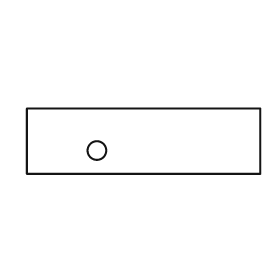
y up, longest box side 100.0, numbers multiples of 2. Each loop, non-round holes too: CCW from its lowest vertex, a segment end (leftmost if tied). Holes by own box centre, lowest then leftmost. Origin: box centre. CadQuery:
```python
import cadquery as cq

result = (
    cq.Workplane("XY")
    .moveTo(-50.0, -14.0)
    .lineTo(50.0, -14.0)
    .lineTo(50.0, 14.0)
    .lineTo(-50.0, 14.0)
    .close()
    .moveTo(-20.0, -4.0)
    .circle(4.0)
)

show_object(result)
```